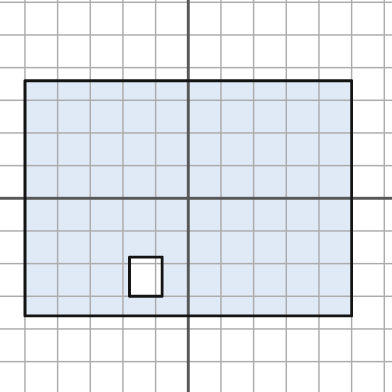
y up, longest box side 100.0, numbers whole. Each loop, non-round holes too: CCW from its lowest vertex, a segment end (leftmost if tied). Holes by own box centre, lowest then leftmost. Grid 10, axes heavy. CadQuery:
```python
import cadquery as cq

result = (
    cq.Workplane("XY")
    .moveTo(-50.0, -36.0)
    .lineTo(50.0, -36.0)
    .lineTo(50.0, 36.0)
    .lineTo(-50.0, 36.0)
    .close()
    .moveTo(-18.0, -30.0)
    .lineTo(-8.0, -30.0)
    .lineTo(-8.0, -18.0)
    .lineTo(-18.0, -18.0)
    .close()
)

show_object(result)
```